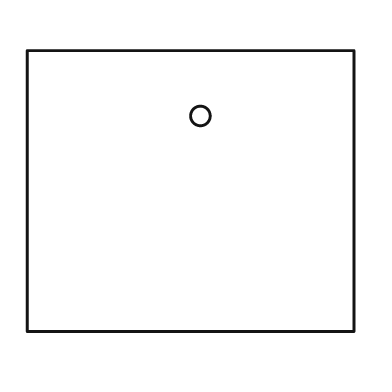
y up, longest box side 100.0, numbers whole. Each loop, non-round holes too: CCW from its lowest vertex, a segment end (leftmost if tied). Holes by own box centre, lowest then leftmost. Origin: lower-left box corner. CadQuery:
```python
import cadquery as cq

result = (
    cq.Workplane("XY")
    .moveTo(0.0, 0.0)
    .lineTo(100.0, 0.0)
    .lineTo(100.0, 86.0)
    .lineTo(0.0, 86.0)
    .close()
    .moveTo(53.0, 66.0)
    .circle(3.0)
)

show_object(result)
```